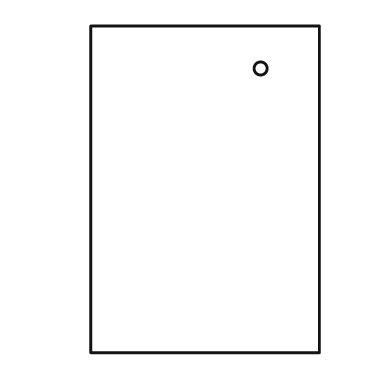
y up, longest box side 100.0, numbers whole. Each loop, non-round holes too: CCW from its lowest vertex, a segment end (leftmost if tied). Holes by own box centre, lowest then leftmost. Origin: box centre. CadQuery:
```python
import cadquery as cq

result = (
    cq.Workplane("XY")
    .moveTo(-35.0, -50.0)
    .lineTo(35.0, -50.0)
    .lineTo(35.0, 50.0)
    .lineTo(-35.0, 50.0)
    .close()
    .moveTo(17.0, 37.0)
    .circle(2.0)
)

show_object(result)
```